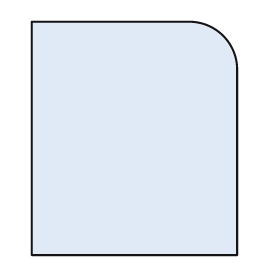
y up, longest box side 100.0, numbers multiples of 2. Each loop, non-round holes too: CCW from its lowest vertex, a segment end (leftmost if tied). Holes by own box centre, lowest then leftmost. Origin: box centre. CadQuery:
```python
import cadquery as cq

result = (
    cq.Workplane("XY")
    .moveTo(-44.0, -50.0)
    .lineTo(44.0, -50.0)
    .lineTo(44.0, 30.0)
    .threePointArc((38.0, 44.0), (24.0, 50.0))
    .lineTo(-44.0, 50.0)
    .close()
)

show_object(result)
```